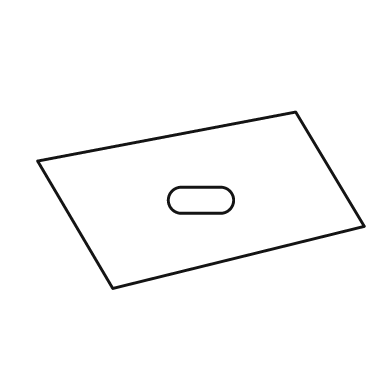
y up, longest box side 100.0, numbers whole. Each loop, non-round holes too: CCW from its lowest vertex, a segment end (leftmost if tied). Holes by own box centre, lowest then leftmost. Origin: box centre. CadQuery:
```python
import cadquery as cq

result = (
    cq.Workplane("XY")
    .moveTo(-27.0, -27.0)
    .lineTo(50.0, -8.0)
    .lineTo(29.0, 27.0)
    .lineTo(-50.0, 12.0)
    .close()
    .moveTo(-6.0, -4.0)
    .lineTo(6.0, -4.0)
    .threePointArc((10.0, 0.0), (6.0, 4.0))
    .lineTo(-6.0, 4.0)
    .threePointArc((-10.0, 0.0), (-6.0, -4.0))
    .close()
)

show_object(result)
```